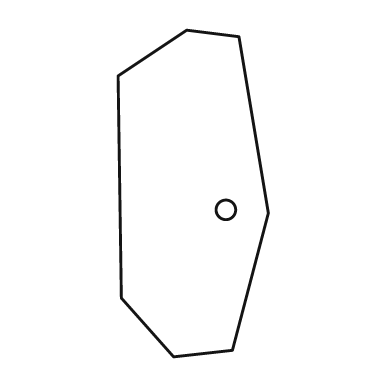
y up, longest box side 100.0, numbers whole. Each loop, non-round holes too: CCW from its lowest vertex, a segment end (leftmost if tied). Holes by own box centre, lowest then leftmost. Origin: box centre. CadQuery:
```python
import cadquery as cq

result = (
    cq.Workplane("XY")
    .moveTo(-6.0, -50.0)
    .lineTo(12.0, -48.0)
    .lineTo(23.0, -6.0)
    .lineTo(14.0, 48.0)
    .lineTo(-2.0, 50.0)
    .lineTo(-23.0, 36.0)
    .lineTo(-22.0, -32.0)
    .close()
    .moveTo(10.0, -5.0)
    .circle(3.0)
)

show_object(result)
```